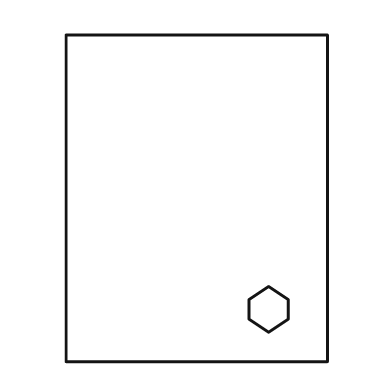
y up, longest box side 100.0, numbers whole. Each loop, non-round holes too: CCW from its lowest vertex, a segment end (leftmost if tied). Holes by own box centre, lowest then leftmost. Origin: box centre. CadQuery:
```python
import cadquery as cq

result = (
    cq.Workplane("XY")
    .moveTo(-40.0, -50.0)
    .lineTo(40.0, -50.0)
    .lineTo(40.0, 50.0)
    .lineTo(-40.0, 50.0)
    .close()
    .moveTo(22.0, -41.0)
    .lineTo(28.0, -37.0)
    .lineTo(28.0, -31.0)
    .lineTo(22.0, -27.0)
    .lineTo(16.0, -31.0)
    .lineTo(16.0, -37.0)
    .close()
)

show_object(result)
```